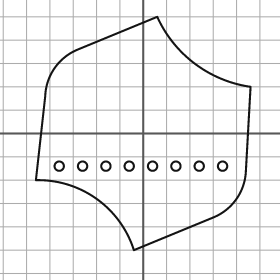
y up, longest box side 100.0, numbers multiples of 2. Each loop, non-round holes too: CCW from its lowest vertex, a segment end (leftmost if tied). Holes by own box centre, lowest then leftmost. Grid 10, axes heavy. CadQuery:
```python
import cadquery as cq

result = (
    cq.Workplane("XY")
    .moveTo(-4.0, -50.0)
    .lineTo(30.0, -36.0)
    .threePointArc((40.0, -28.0), (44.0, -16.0))
    .lineTo(46.0, 20.0)
    .threePointArc((22.0, 30.0), (6.0, 50.0))
    .lineTo(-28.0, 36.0)
    .threePointArc((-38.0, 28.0), (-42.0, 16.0))
    .lineTo(-46.0, -20.0)
    .threePointArc((-20.0, -28.0), (-4.0, -50.0))
    .close()
    .moveTo(-36.0, -14.0)
    .circle(2.0)
    .moveTo(-26.0, -14.0)
    .circle(2.0)
    .moveTo(-16.0, -14.0)
    .circle(2.0)
    .moveTo(-6.0, -14.0)
    .circle(2.0)
    .moveTo(4.0, -14.0)
    .circle(2.0)
    .moveTo(14.0, -14.0)
    .circle(2.0)
    .moveTo(24.0, -14.0)
    .circle(2.0)
    .moveTo(34.0, -14.0)
    .circle(2.0)
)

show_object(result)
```